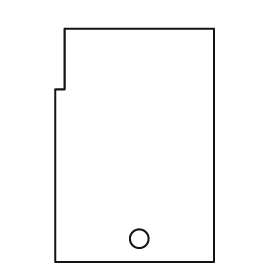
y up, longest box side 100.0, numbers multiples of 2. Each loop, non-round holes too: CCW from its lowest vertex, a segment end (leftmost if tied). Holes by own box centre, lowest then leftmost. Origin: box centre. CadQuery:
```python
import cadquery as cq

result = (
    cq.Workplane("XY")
    .moveTo(-34.0, -50.0)
    .lineTo(34.0, -50.0)
    .lineTo(34.0, 50.0)
    .lineTo(-30.0, 50.0)
    .lineTo(-30.0, 24.0)
    .lineTo(-34.0, 24.0)
    .close()
    .moveTo(2.0, -40.0)
    .circle(4.0)
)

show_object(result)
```